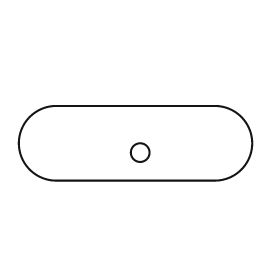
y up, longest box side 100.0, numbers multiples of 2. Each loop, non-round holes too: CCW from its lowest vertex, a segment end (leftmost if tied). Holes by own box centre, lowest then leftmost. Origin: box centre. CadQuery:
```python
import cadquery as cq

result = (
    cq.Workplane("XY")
    .moveTo(-34.0, -16.0)
    .lineTo(34.0, -16.0)
    .threePointArc((50.0, 0.0), (34.0, 16.0))
    .lineTo(-34.0, 16.0)
    .threePointArc((-50.0, 0.0), (-34.0, -16.0))
    .close()
    .moveTo(2.0, -4.0)
    .circle(4.0)
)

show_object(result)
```